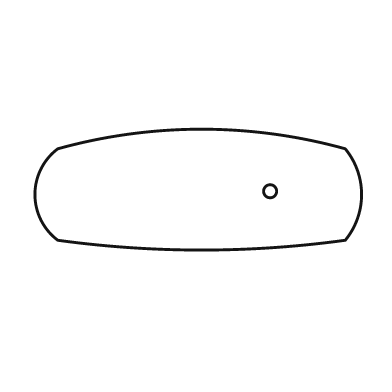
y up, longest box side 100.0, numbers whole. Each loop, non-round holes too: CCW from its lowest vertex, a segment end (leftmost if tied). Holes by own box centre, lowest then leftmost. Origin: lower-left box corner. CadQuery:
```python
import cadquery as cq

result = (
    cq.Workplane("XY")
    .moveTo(7.0, 3.0)
    .threePointArc((51.0, 0.0), (95.0, 3.0))
    .threePointArc((100.0, 17.0), (95.0, 31.0))
    .threePointArc((51.0, 37.0), (7.0, 31.0))
    .threePointArc((0.0, 17.0), (7.0, 3.0))
    .close()
    .moveTo(72.0, 18.0)
    .circle(2.0)
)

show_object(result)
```